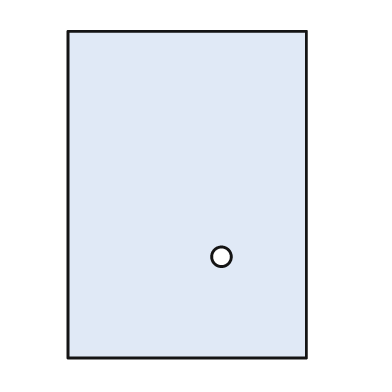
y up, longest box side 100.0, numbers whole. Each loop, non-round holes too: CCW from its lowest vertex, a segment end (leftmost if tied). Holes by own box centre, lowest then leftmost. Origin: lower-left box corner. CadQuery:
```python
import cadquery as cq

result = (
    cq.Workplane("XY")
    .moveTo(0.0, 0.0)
    .lineTo(73.0, 0.0)
    .lineTo(73.0, 100.0)
    .lineTo(0.0, 100.0)
    .close()
    .moveTo(47.0, 31.0)
    .circle(3.0)
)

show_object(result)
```